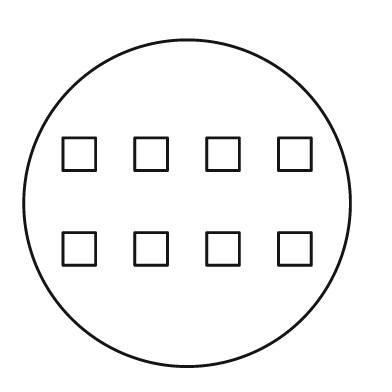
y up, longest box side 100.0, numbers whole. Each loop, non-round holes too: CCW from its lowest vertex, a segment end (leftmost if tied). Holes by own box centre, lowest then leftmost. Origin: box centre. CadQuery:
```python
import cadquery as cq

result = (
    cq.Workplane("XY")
    .moveTo(0.0, 0.0)
    .circle(50.0)
    .moveTo(-38.0, -19.0)
    .lineTo(-28.0, -19.0)
    .lineTo(-28.0, -9.0)
    .lineTo(-38.0, -9.0)
    .close()
    .moveTo(-16.0, -19.0)
    .lineTo(-6.0, -19.0)
    .lineTo(-6.0, -9.0)
    .lineTo(-16.0, -9.0)
    .close()
    .moveTo(6.0, -19.0)
    .lineTo(16.0, -19.0)
    .lineTo(16.0, -9.0)
    .lineTo(6.0, -9.0)
    .close()
    .moveTo(28.0, -19.0)
    .lineTo(38.0, -19.0)
    .lineTo(38.0, -9.0)
    .lineTo(28.0, -9.0)
    .close()
    .moveTo(-38.0, 10.0)
    .lineTo(-28.0, 10.0)
    .lineTo(-28.0, 20.0)
    .lineTo(-38.0, 20.0)
    .close()
    .moveTo(-16.0, 10.0)
    .lineTo(-6.0, 10.0)
    .lineTo(-6.0, 20.0)
    .lineTo(-16.0, 20.0)
    .close()
    .moveTo(6.0, 10.0)
    .lineTo(16.0, 10.0)
    .lineTo(16.0, 20.0)
    .lineTo(6.0, 20.0)
    .close()
    .moveTo(28.0, 10.0)
    .lineTo(38.0, 10.0)
    .lineTo(38.0, 20.0)
    .lineTo(28.0, 20.0)
    .close()
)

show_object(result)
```